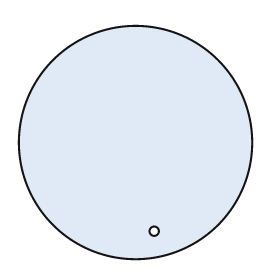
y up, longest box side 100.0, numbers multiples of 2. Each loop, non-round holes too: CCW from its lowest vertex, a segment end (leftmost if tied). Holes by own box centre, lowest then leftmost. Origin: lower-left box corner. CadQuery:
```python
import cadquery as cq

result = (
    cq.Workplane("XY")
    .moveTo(50.0, 50.0)
    .circle(50.0)
    .moveTo(58.0, 12.0)
    .circle(2.0)
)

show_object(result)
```